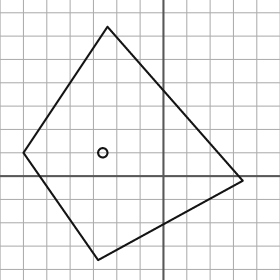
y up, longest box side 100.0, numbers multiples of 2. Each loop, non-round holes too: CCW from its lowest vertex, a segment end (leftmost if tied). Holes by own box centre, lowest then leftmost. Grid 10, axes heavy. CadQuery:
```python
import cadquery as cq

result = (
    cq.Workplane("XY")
    .moveTo(-28.0, -36.0)
    .lineTo(34.0, -2.0)
    .lineTo(-24.0, 64.0)
    .lineTo(-60.0, 10.0)
    .close()
    .moveTo(-26.0, 10.0)
    .circle(2.0)
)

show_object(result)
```